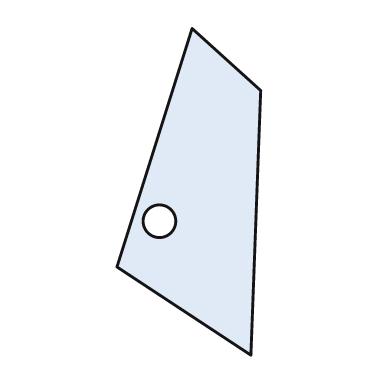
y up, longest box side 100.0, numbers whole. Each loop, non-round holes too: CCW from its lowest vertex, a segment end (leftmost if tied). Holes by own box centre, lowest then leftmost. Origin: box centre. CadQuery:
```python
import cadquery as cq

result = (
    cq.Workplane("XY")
    .moveTo(19.0, -50.0)
    .lineTo(22.0, 31.0)
    .lineTo(1.0, 50.0)
    .lineTo(-22.0, -23.0)
    .close()
    .moveTo(-9.0, -9.0)
    .circle(5.0)
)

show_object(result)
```